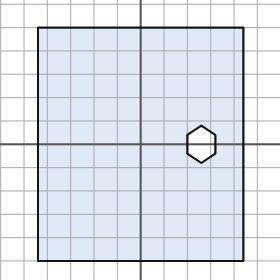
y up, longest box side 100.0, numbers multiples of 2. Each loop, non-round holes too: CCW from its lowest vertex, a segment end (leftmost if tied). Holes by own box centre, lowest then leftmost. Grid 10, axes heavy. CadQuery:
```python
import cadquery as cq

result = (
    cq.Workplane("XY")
    .moveTo(-44.0, -50.0)
    .lineTo(44.0, -50.0)
    .lineTo(44.0, 50.0)
    .lineTo(-44.0, 50.0)
    .close()
    .moveTo(26.0, -8.0)
    .lineTo(32.0, -4.0)
    .lineTo(32.0, 4.0)
    .lineTo(26.0, 8.0)
    .lineTo(20.0, 4.0)
    .lineTo(20.0, -4.0)
    .close()
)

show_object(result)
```